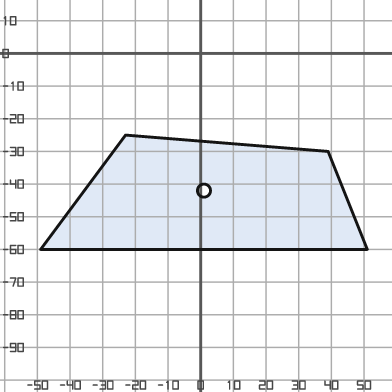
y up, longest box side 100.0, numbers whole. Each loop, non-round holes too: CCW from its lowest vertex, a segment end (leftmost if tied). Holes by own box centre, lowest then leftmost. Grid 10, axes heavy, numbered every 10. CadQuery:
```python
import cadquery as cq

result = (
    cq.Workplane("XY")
    .moveTo(-49.0, -60.0)
    .lineTo(51.0, -60.0)
    .lineTo(39.0, -30.0)
    .lineTo(-23.0, -25.0)
    .close()
    .moveTo(1.0, -42.0)
    .circle(2.0)
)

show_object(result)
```